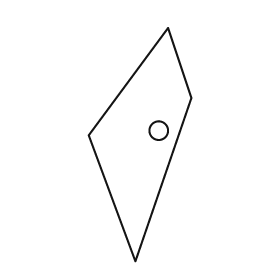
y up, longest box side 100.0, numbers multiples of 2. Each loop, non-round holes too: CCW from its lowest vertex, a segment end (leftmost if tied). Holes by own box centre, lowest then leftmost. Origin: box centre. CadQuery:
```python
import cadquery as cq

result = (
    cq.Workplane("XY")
    .moveTo(-2.0, -50.0)
    .lineTo(22.0, 20.0)
    .lineTo(12.0, 50.0)
    .lineTo(-22.0, 4.0)
    .close()
    .moveTo(8.0, 6.0)
    .circle(4.0)
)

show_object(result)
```